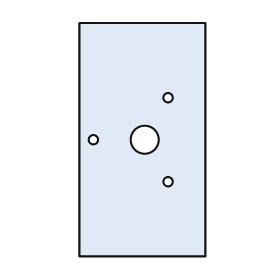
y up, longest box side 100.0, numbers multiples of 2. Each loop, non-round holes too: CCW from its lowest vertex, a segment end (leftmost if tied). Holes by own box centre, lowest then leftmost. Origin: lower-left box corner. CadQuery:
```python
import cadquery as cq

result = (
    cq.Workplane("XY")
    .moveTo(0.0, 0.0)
    .lineTo(54.0, 0.0)
    .lineTo(54.0, 100.0)
    .lineTo(0.0, 100.0)
    .close()
    .moveTo(38.0, 32.0)
    .circle(2.0)
    .moveTo(6.0, 50.0)
    .circle(2.0)
    .moveTo(28.0, 50.0)
    .circle(6.0)
    .moveTo(38.0, 68.0)
    .circle(2.0)
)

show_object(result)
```